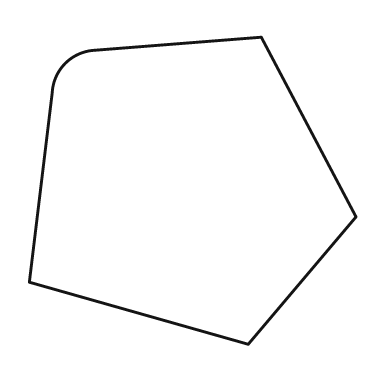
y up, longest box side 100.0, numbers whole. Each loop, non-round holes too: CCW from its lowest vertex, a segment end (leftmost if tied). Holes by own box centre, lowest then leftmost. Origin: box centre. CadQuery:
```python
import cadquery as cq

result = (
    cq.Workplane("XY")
    .moveTo(17.0, -47.0)
    .lineTo(50.0, -8.0)
    .lineTo(21.0, 47.0)
    .lineTo(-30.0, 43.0)
    .threePointArc((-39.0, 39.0), (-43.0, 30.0))
    .lineTo(-50.0, -28.0)
    .close()
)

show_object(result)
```